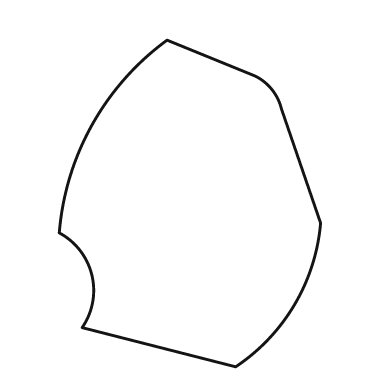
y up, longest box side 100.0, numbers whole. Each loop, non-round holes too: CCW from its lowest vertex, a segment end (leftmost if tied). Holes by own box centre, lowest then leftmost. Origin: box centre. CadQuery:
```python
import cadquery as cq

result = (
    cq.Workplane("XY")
    .moveTo(14.0, -50.0)
    .threePointArc((32.0, -31.0), (40.0, -6.0))
    .lineTo(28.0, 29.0)
    .threePointArc((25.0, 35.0), (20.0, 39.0))
    .lineTo(-7.0, 50.0)
    .threePointArc((-30.0, 24.0), (-40.0, -9.0))
    .threePointArc((-30.0, -22.0), (-33.0, -38.0))
    .close()
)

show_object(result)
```